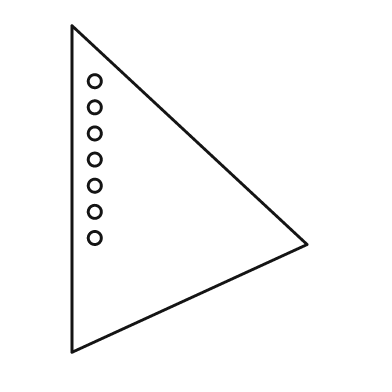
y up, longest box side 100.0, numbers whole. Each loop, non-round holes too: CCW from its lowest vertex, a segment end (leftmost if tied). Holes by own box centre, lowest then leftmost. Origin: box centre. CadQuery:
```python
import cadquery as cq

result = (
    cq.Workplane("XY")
    .moveTo(-36.0, -50.0)
    .lineTo(36.0, -17.0)
    .lineTo(-36.0, 50.0)
    .close()
    .moveTo(-29.0, -15.0)
    .circle(2.0)
    .moveTo(-29.0, -7.0)
    .circle(2.0)
    .moveTo(-29.0, 1.0)
    .circle(2.0)
    .moveTo(-29.0, 9.0)
    .circle(2.0)
    .moveTo(-29.0, 17.0)
    .circle(2.0)
    .moveTo(-29.0, 25.0)
    .circle(2.0)
    .moveTo(-29.0, 33.0)
    .circle(2.0)
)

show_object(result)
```